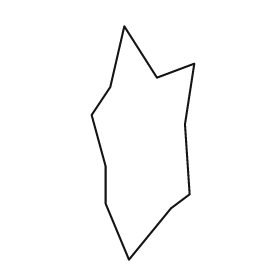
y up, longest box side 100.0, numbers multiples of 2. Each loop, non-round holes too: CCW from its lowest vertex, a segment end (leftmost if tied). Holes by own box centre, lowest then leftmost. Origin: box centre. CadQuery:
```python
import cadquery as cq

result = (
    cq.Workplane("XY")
    .moveTo(-6.0, -50.0)
    .lineTo(12.0, -28.0)
    .lineTo(20.0, -22.0)
    .lineTo(18.0, 8.0)
    .lineTo(22.0, 34.0)
    .lineTo(6.0, 28.0)
    .lineTo(-8.0, 50.0)
    .lineTo(-14.0, 24.0)
    .lineTo(-22.0, 12.0)
    .lineTo(-16.0, -10.0)
    .lineTo(-16.0, -26.0)
    .close()
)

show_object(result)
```